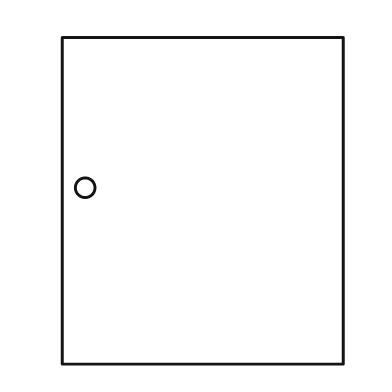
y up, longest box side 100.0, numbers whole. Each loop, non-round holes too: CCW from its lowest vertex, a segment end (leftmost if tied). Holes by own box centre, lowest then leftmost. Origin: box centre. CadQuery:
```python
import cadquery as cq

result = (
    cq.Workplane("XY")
    .moveTo(-43.0, -50.0)
    .lineTo(43.0, -50.0)
    .lineTo(43.0, 50.0)
    .lineTo(-43.0, 50.0)
    .close()
    .moveTo(-36.0, 4.0)
    .circle(3.0)
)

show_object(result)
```